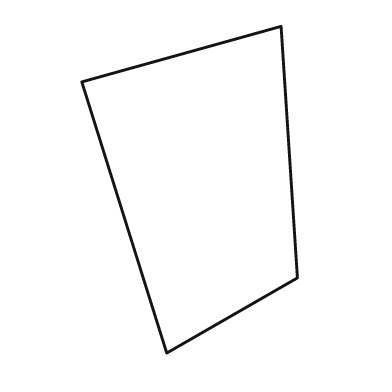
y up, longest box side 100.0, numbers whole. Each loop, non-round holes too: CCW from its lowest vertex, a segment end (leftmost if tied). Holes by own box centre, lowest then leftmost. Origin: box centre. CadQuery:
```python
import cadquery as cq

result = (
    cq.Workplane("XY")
    .moveTo(-7.0, -50.0)
    .lineTo(33.0, -27.0)
    .lineTo(28.0, 50.0)
    .lineTo(-33.0, 33.0)
    .close()
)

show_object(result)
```